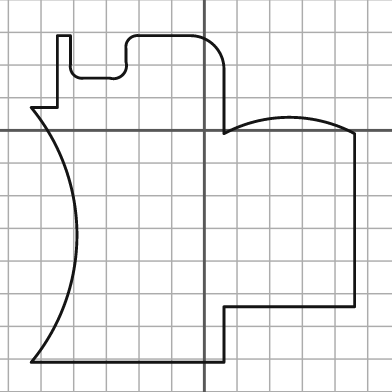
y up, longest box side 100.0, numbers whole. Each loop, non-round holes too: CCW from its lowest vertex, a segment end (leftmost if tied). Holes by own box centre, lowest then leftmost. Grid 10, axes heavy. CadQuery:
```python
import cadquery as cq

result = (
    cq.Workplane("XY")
    .moveTo(-53.0, -71.0)
    .lineTo(6.0, -71.0)
    .lineTo(6.0, -54.0)
    .lineTo(46.0, -54.0)
    .lineTo(46.0, -1.0)
    .threePointArc((26.0, 4.0), (6.0, -1.0))
    .lineTo(6.0, 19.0)
    .threePointArc((3.0, 26.0), (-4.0, 29.0))
    .lineTo(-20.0, 29.0)
    .threePointArc((-23.0, 28.0), (-24.0, 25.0))
    .lineTo(-24.0, 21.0)
    .threePointArc((-25.0, 17.0), (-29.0, 16.0))
    .lineTo(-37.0, 16.0)
    .threePointArc((-40.0, 17.0), (-41.0, 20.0))
    .lineTo(-41.0, 29.0)
    .lineTo(-45.0, 29.0)
    .lineTo(-45.0, 7.0)
    .lineTo(-53.0, 7.0)
    .threePointArc((-39.0, -32.0), (-53.0, -71.0))
    .close()
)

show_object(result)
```